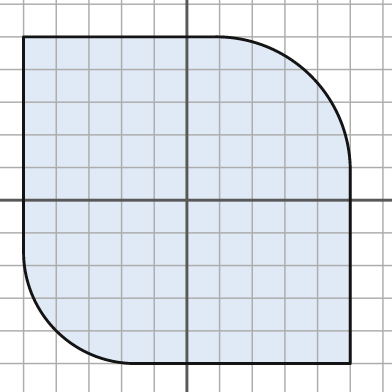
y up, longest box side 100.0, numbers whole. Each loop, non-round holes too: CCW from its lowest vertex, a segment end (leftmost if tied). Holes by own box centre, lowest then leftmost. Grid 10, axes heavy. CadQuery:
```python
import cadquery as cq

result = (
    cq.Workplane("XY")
    .moveTo(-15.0, -50.0)
    .lineTo(50.0, -50.0)
    .lineTo(50.0, 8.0)
    .threePointArc((38.0, 38.0), (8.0, 50.0))
    .lineTo(-50.0, 50.0)
    .lineTo(-50.0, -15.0)
    .threePointArc((-40.0, -40.0), (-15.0, -50.0))
    .close()
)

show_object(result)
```